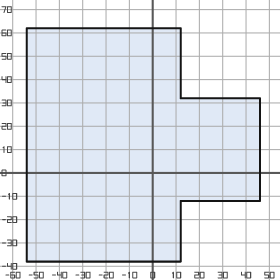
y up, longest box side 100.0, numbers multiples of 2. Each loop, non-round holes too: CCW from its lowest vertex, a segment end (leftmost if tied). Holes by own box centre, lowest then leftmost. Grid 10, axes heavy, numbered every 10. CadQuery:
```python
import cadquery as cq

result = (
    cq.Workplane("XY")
    .moveTo(-54.0, -38.0)
    .lineTo(12.0, -38.0)
    .lineTo(12.0, -12.0)
    .lineTo(46.0, -12.0)
    .lineTo(46.0, 32.0)
    .lineTo(12.0, 32.0)
    .lineTo(12.0, 62.0)
    .lineTo(-54.0, 62.0)
    .close()
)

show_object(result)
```